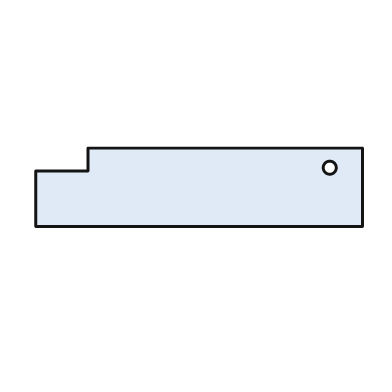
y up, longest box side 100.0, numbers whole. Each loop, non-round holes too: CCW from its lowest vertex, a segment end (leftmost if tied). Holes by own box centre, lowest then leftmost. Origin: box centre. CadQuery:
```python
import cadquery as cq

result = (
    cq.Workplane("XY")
    .moveTo(-50.0, -12.0)
    .lineTo(50.0, -12.0)
    .lineTo(50.0, 12.0)
    .lineTo(-34.0, 12.0)
    .lineTo(-34.0, 5.0)
    .lineTo(-50.0, 5.0)
    .close()
    .moveTo(40.0, 6.0)
    .circle(2.0)
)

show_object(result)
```